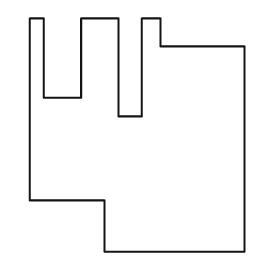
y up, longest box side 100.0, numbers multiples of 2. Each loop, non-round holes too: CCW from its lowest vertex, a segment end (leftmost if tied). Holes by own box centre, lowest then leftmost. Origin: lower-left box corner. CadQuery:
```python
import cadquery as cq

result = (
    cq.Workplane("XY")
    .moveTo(32.0, 0.0)
    .lineTo(92.0, 0.0)
    .lineTo(92.0, 88.0)
    .lineTo(56.0, 88.0)
    .lineTo(56.0, 100.0)
    .lineTo(48.0, 100.0)
    .lineTo(48.0, 58.0)
    .lineTo(38.0, 58.0)
    .lineTo(38.0, 100.0)
    .lineTo(22.0, 100.0)
    .lineTo(22.0, 66.0)
    .lineTo(6.0, 66.0)
    .lineTo(6.0, 100.0)
    .lineTo(0.0, 100.0)
    .lineTo(0.0, 22.0)
    .lineTo(32.0, 22.0)
    .close()
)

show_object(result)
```